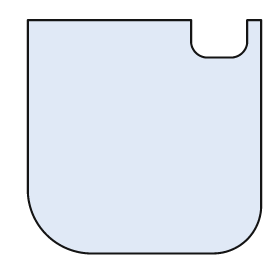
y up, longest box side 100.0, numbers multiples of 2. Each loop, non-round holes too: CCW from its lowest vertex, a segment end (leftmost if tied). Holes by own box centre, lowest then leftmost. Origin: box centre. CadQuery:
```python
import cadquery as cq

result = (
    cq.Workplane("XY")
    .moveTo(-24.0, -50.0)
    .lineTo(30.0, -50.0)
    .threePointArc((44.0, -44.0), (50.0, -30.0))
    .lineTo(50.0, 50.0)
    .lineTo(44.0, 50.0)
    .lineTo(44.0, 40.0)
    .threePointArc((42.0, 36.0), (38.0, 34.0))
    .lineTo(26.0, 34.0)
    .threePointArc((22.0, 36.0), (20.0, 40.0))
    .lineTo(20.0, 50.0)
    .lineTo(-50.0, 50.0)
    .lineTo(-50.0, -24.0)
    .threePointArc((-42.0, -42.0), (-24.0, -50.0))
    .close()
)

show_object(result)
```